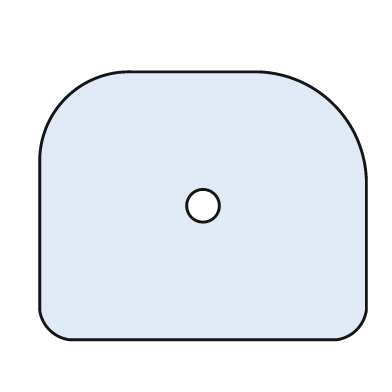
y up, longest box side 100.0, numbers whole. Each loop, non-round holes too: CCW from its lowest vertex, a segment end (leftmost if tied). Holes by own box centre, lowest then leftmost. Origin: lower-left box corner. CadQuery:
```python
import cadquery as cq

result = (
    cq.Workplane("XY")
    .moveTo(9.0, 0.0)
    .lineTo(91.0, 0.0)
    .threePointArc((97.0, 3.0), (100.0, 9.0))
    .lineTo(100.0, 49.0)
    .threePointArc((90.0, 72.0), (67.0, 82.0))
    .lineTo(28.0, 82.0)
    .threePointArc((8.0, 74.0), (0.0, 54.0))
    .lineTo(0.0, 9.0)
    .threePointArc((3.0, 3.0), (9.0, 0.0))
    .close()
    .moveTo(50.0, 41.0)
    .circle(5.0)
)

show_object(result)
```